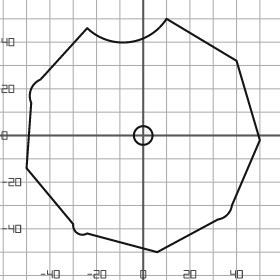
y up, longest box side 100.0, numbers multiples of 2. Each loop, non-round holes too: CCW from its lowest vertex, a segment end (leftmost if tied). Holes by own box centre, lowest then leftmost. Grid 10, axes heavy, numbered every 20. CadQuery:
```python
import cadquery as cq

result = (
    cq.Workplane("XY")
    .moveTo(6.0, -50.0)
    .lineTo(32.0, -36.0)
    .threePointArc((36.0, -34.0), (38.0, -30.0))
    .lineTo(50.0, -2.0)
    .lineTo(40.0, 32.0)
    .lineTo(10.0, 50.0)
    .threePointArc((-6.0, 40.0), (-24.0, 46.0))
    .lineTo(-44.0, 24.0)
    .threePointArc((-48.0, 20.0), (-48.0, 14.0))
    .lineTo(-50.0, -14.0)
    .lineTo(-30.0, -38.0)
    .threePointArc((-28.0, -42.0), (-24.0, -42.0))
    .close()
    .moveTo(0.0, 0.0)
    .circle(4.0)
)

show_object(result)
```